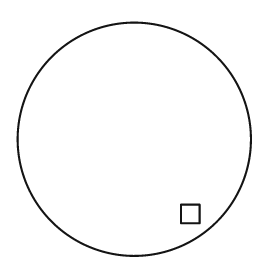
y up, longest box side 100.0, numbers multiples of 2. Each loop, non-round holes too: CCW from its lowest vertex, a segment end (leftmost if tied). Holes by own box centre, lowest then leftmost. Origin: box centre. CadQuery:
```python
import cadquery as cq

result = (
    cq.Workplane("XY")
    .moveTo(0.0, 0.0)
    .circle(50.0)
    .moveTo(20.0, -36.0)
    .lineTo(28.0, -36.0)
    .lineTo(28.0, -28.0)
    .lineTo(20.0, -28.0)
    .close()
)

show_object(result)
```